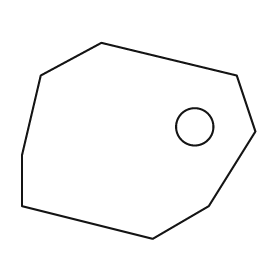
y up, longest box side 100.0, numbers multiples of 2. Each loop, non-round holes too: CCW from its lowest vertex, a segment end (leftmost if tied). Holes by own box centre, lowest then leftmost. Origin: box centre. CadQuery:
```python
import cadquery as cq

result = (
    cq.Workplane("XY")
    .moveTo(6.0, -42.0)
    .lineTo(30.0, -28.0)
    .lineTo(50.0, 4.0)
    .lineTo(42.0, 28.0)
    .lineTo(-16.0, 42.0)
    .lineTo(-42.0, 28.0)
    .lineTo(-50.0, -6.0)
    .lineTo(-50.0, -28.0)
    .close()
    .moveTo(24.0, 6.0)
    .circle(8.0)
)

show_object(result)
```